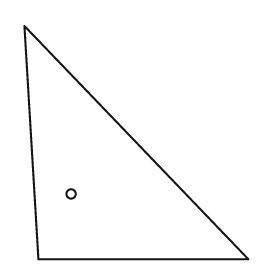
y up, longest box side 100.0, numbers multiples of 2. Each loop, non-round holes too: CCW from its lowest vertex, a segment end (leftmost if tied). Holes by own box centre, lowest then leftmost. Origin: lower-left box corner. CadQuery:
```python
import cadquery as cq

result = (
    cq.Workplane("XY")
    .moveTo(6.0, 0.0)
    .lineTo(96.0, 0.0)
    .lineTo(0.0, 100.0)
    .close()
    .moveTo(20.0, 28.0)
    .circle(2.0)
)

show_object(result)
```